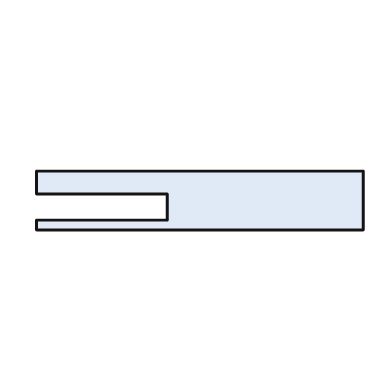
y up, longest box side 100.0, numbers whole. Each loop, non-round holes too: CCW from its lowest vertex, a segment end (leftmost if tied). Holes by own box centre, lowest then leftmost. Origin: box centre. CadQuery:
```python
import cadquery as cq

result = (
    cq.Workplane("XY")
    .moveTo(-50.0, -9.0)
    .lineTo(50.0, -9.0)
    .lineTo(50.0, 9.0)
    .lineTo(-50.0, 9.0)
    .lineTo(-50.0, 2.0)
    .lineTo(-10.0, 2.0)
    .lineTo(-10.0, -6.0)
    .lineTo(-50.0, -6.0)
    .close()
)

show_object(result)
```